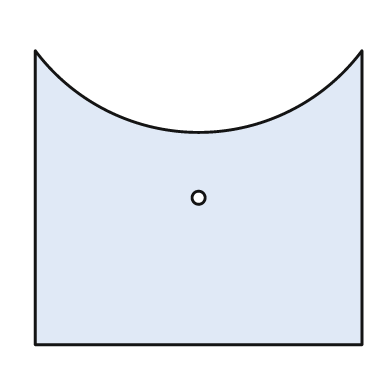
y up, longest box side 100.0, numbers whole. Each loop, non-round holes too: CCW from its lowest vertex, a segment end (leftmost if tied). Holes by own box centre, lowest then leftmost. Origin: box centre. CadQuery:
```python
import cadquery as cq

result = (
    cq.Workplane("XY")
    .moveTo(-50.0, -45.0)
    .lineTo(50.0, -45.0)
    .lineTo(50.0, 45.0)
    .threePointArc((0.0, 20.0), (-50.0, 45.0))
    .close()
    .moveTo(0.0, 0.0)
    .circle(2.0)
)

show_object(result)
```